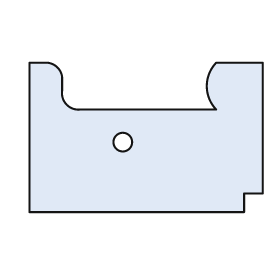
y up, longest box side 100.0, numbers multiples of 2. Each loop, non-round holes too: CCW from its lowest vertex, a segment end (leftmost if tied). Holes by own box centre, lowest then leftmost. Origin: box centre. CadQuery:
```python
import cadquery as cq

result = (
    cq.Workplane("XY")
    .moveTo(-50.0, -32.0)
    .lineTo(42.0, -32.0)
    .lineTo(42.0, -24.0)
    .lineTo(50.0, -24.0)
    .lineTo(50.0, 32.0)
    .lineTo(30.0, 32.0)
    .threePointArc((26.0, 22.0), (30.0, 12.0))
    .lineTo(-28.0, 12.0)
    .threePointArc((-34.0, 14.0), (-36.0, 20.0))
    .lineTo(-36.0, 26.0)
    .threePointArc((-38.0, 30.0), (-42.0, 32.0))
    .lineTo(-50.0, 32.0)
    .close()
    .moveTo(-10.0, -2.0)
    .circle(4.0)
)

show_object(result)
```